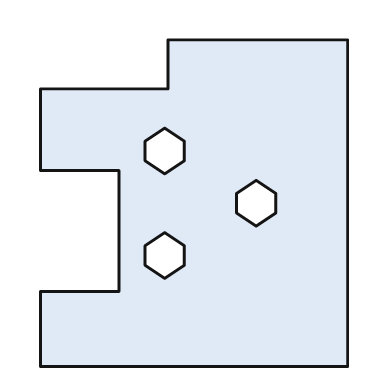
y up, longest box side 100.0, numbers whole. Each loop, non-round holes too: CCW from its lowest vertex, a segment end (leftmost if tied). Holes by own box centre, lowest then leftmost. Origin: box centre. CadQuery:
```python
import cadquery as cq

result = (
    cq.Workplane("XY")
    .moveTo(-47.0, -50.0)
    .lineTo(47.0, -50.0)
    .lineTo(47.0, 50.0)
    .lineTo(-8.0, 50.0)
    .lineTo(-8.0, 35.0)
    .lineTo(-47.0, 35.0)
    .lineTo(-47.0, 10.0)
    .lineTo(-23.0, 10.0)
    .lineTo(-23.0, -27.0)
    .lineTo(-47.0, -27.0)
    .close()
    .moveTo(-9.0, -23.0)
    .lineTo(-3.0, -19.0)
    .lineTo(-3.0, -13.0)
    .lineTo(-9.0, -9.0)
    .lineTo(-15.0, -13.0)
    .lineTo(-15.0, -19.0)
    .close()
    .moveTo(19.0, -7.0)
    .lineTo(25.0, -3.0)
    .lineTo(25.0, 3.0)
    .lineTo(19.0, 7.0)
    .lineTo(13.0, 3.0)
    .lineTo(13.0, -3.0)
    .close()
    .moveTo(-9.0, 9.0)
    .lineTo(-3.0, 13.0)
    .lineTo(-3.0, 19.0)
    .lineTo(-9.0, 23.0)
    .lineTo(-15.0, 19.0)
    .lineTo(-15.0, 13.0)
    .close()
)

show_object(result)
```